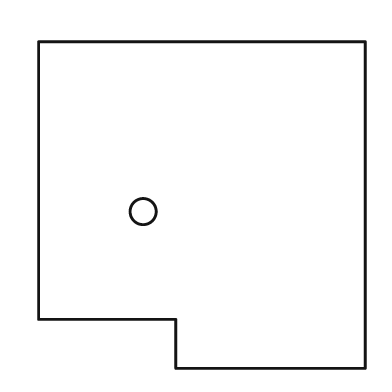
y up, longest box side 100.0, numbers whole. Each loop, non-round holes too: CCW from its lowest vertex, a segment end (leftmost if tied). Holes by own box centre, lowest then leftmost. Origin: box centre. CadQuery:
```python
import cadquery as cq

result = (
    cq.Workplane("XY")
    .moveTo(-8.0, -50.0)
    .lineTo(50.0, -50.0)
    .lineTo(50.0, 50.0)
    .lineTo(-50.0, 50.0)
    .lineTo(-50.0, -35.0)
    .lineTo(-8.0, -35.0)
    .close()
    .moveTo(-18.0, -2.0)
    .circle(4.0)
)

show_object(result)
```